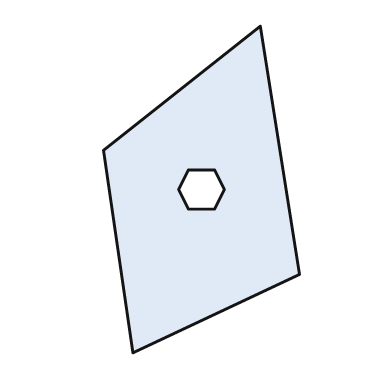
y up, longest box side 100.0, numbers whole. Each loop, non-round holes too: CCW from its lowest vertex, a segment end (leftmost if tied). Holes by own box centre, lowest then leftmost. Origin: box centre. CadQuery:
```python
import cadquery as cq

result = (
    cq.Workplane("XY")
    .moveTo(-21.0, -50.0)
    .lineTo(30.0, -26.0)
    .lineTo(18.0, 50.0)
    .lineTo(-30.0, 12.0)
    .close()
    .moveTo(-4.0, -6.0)
    .lineTo(4.0, -6.0)
    .lineTo(7.0, 0.0)
    .lineTo(4.0, 6.0)
    .lineTo(-4.0, 6.0)
    .lineTo(-7.0, 0.0)
    .close()
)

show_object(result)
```